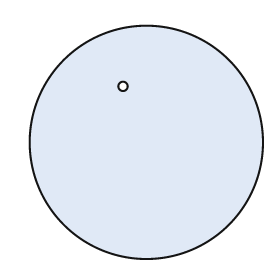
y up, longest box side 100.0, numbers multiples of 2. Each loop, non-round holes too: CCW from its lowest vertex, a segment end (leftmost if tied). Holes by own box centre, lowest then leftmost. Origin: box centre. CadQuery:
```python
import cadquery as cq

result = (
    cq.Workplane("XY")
    .moveTo(0.0, 0.0)
    .circle(50.0)
    .moveTo(-10.0, 24.0)
    .circle(2.0)
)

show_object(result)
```